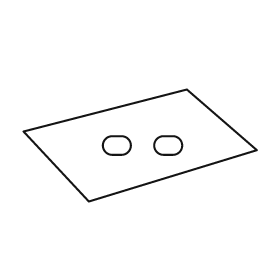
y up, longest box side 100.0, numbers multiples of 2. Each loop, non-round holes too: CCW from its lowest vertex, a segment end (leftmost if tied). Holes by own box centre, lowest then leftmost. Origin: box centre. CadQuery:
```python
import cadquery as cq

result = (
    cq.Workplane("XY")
    .moveTo(-22.0, -24.0)
    .lineTo(50.0, -2.0)
    .lineTo(20.0, 24.0)
    .lineTo(-50.0, 6.0)
    .close()
    .moveTo(-12.0, -4.0)
    .lineTo(-8.0, -4.0)
    .threePointArc((-4.0, 0.0), (-8.0, 4.0))
    .lineTo(-12.0, 4.0)
    .threePointArc((-16.0, 0.0), (-12.0, -4.0))
    .close()
    .moveTo(10.0, -4.0)
    .lineTo(14.0, -4.0)
    .threePointArc((18.0, 0.0), (14.0, 4.0))
    .lineTo(10.0, 4.0)
    .threePointArc((6.0, 0.0), (10.0, -4.0))
    .close()
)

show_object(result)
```